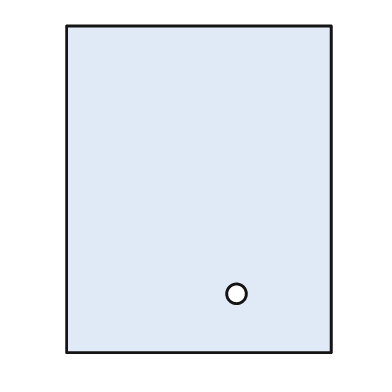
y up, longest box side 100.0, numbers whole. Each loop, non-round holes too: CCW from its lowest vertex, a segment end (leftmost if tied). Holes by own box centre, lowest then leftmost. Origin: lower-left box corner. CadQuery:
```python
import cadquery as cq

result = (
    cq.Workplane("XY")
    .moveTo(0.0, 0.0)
    .lineTo(81.0, 0.0)
    .lineTo(81.0, 100.0)
    .lineTo(0.0, 100.0)
    .close()
    .moveTo(52.0, 18.0)
    .circle(3.0)
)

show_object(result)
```